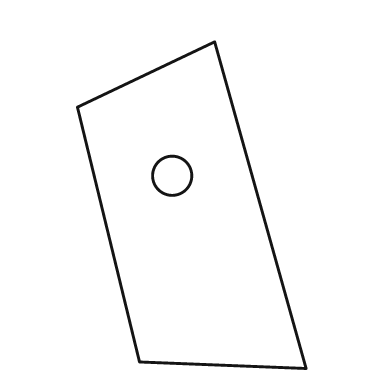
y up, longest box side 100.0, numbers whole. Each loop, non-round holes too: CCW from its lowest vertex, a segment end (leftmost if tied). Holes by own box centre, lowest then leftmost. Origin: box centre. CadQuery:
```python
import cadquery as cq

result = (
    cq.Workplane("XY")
    .moveTo(35.0, -50.0)
    .lineTo(7.0, 50.0)
    .lineTo(-35.0, 30.0)
    .lineTo(-16.0, -48.0)
    .close()
    .moveTo(-6.0, 9.0)
    .circle(6.0)
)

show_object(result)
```